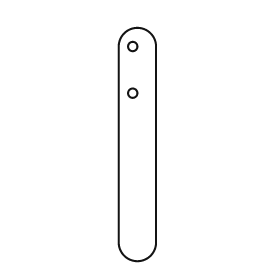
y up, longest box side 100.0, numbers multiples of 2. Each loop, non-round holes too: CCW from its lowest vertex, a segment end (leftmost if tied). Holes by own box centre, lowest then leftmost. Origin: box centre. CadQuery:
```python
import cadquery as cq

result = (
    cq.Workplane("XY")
    .moveTo(-8.0, -42.0)
    .threePointArc((0.0, -50.0), (8.0, -42.0))
    .lineTo(8.0, 42.0)
    .threePointArc((0.0, 50.0), (-8.0, 42.0))
    .close()
    .moveTo(-2.0, 22.0)
    .circle(2.0)
    .moveTo(-2.0, 42.0)
    .circle(2.0)
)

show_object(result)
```